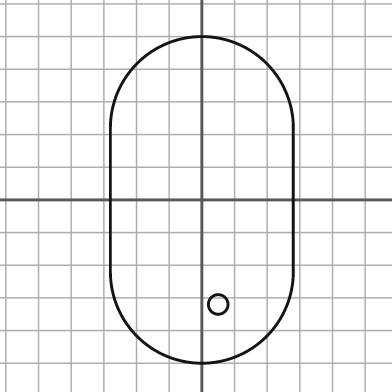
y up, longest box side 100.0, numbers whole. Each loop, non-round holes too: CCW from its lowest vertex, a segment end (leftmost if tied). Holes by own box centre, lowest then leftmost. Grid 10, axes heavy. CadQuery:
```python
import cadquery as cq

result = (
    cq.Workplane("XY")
    .moveTo(-28.0, -22.0)
    .threePointArc((0.0, -50.0), (28.0, -22.0))
    .lineTo(28.0, 22.0)
    .threePointArc((0.0, 50.0), (-28.0, 22.0))
    .close()
    .moveTo(5.0, -32.0)
    .circle(3.0)
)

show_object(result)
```